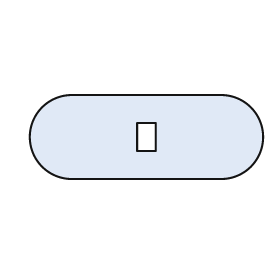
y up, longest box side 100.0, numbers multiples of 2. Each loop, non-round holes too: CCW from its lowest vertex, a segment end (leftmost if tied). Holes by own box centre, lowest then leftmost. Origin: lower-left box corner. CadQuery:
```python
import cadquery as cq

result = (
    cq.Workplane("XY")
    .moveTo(18.0, 0.0)
    .lineTo(82.0, 0.0)
    .threePointArc((100.0, 18.0), (82.0, 36.0))
    .lineTo(18.0, 36.0)
    .threePointArc((0.0, 18.0), (18.0, 0.0))
    .close()
    .moveTo(46.0, 12.0)
    .lineTo(54.0, 12.0)
    .lineTo(54.0, 24.0)
    .lineTo(46.0, 24.0)
    .close()
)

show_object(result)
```